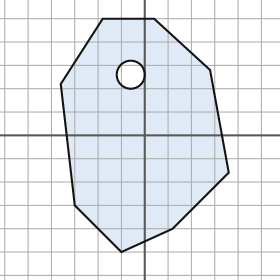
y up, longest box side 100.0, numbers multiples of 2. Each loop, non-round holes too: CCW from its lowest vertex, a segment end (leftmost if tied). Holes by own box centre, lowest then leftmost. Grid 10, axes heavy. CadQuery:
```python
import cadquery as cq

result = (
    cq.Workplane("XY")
    .moveTo(-10.0, -50.0)
    .lineTo(12.0, -40.0)
    .lineTo(36.0, -16.0)
    .lineTo(28.0, 28.0)
    .lineTo(4.0, 50.0)
    .lineTo(-18.0, 50.0)
    .lineTo(-36.0, 22.0)
    .lineTo(-30.0, -30.0)
    .close()
    .moveTo(-6.0, 26.0)
    .circle(6.0)
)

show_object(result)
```